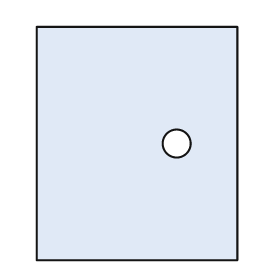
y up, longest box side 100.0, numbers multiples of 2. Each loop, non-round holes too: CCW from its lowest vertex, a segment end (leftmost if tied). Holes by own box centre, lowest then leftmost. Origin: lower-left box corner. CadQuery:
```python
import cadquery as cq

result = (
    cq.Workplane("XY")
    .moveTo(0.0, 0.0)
    .lineTo(86.0, 0.0)
    .lineTo(86.0, 100.0)
    .lineTo(0.0, 100.0)
    .close()
    .moveTo(60.0, 50.0)
    .circle(6.0)
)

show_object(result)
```